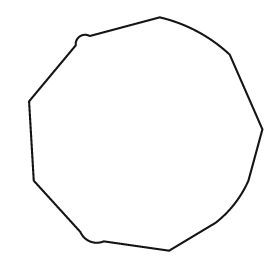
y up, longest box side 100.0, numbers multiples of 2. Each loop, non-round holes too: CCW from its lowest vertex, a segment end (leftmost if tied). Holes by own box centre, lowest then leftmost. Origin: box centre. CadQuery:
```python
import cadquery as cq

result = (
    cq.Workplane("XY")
    .moveTo(10.0, -50.0)
    .lineTo(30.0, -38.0)
    .threePointArc((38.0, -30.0), (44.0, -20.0))
    .lineTo(50.0, 2.0)
    .lineTo(36.0, 34.0)
    .threePointArc((22.0, 44.0), (6.0, 50.0))
    .lineTo(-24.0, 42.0)
    .threePointArc((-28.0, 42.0), (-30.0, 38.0))
    .lineTo(-50.0, 14.0)
    .lineTo(-48.0, -20.0)
    .lineTo(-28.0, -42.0)
    .threePointArc((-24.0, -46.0), (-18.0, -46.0))
    .close()
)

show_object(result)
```